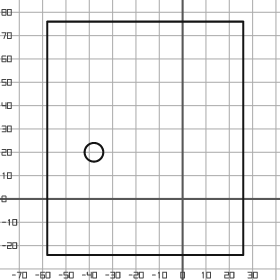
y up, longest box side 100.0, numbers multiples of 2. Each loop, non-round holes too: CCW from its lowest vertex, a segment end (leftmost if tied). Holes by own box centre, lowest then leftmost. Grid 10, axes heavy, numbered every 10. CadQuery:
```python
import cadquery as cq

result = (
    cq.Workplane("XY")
    .moveTo(-58.0, -24.0)
    .lineTo(26.0, -24.0)
    .lineTo(26.0, 76.0)
    .lineTo(-58.0, 76.0)
    .close()
    .moveTo(-38.0, 20.0)
    .circle(4.0)
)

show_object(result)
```